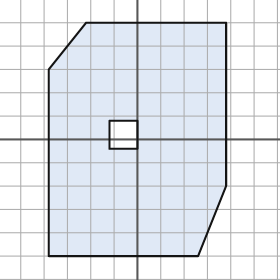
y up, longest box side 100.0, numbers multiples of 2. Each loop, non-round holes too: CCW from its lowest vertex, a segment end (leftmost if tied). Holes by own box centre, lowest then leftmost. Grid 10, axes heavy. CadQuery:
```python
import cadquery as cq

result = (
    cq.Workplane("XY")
    .moveTo(-38.0, -50.0)
    .lineTo(26.0, -50.0)
    .lineTo(38.0, -20.0)
    .lineTo(38.0, 50.0)
    .lineTo(-22.0, 50.0)
    .lineTo(-38.0, 30.0)
    .close()
    .moveTo(-12.0, -4.0)
    .lineTo(0.0, -4.0)
    .lineTo(0.0, 8.0)
    .lineTo(-12.0, 8.0)
    .close()
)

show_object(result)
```